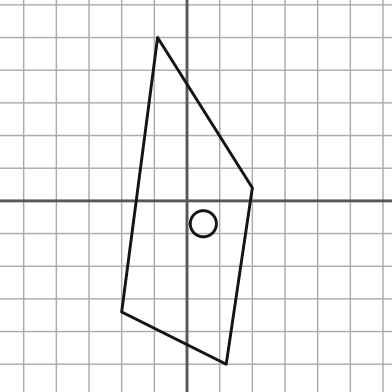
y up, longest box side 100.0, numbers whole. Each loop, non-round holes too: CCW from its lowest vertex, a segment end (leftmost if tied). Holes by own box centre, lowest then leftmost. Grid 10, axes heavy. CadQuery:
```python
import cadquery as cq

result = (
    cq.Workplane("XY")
    .moveTo(12.0, -50.0)
    .lineTo(20.0, 4.0)
    .lineTo(-9.0, 50.0)
    .lineTo(-20.0, -34.0)
    .close()
    .moveTo(5.0, -7.0)
    .circle(4.0)
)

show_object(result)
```